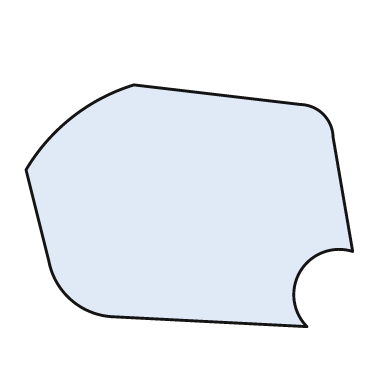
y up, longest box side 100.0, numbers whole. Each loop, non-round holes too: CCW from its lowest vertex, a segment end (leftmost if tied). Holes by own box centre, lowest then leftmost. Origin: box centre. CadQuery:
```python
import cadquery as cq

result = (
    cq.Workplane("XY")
    .moveTo(36.0, -37.0)
    .threePointArc((34.0, -20.0), (50.0, -14.0))
    .lineTo(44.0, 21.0)
    .threePointArc((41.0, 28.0), (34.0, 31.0))
    .lineTo(-17.0, 37.0)
    .threePointArc((-36.0, 27.0), (-50.0, 11.0))
    .lineTo(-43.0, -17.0)
    .threePointArc((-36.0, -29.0), (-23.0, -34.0))
    .close()
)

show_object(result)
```